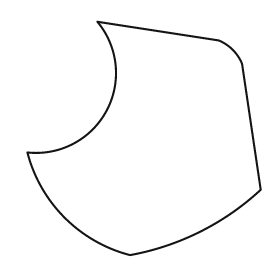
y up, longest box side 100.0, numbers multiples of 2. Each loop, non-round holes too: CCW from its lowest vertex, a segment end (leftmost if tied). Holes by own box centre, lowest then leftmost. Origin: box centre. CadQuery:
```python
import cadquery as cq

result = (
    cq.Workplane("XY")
    .moveTo(-6.0, -50.0)
    .threePointArc((24.0, -40.0), (50.0, -22.0))
    .lineTo(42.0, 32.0)
    .threePointArc((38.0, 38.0), (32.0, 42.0))
    .lineTo(-20.0, 50.0)
    .threePointArc((-16.0, 12.0), (-50.0, -6.0))
    .threePointArc((-34.0, -34.0), (-6.0, -50.0))
    .close()
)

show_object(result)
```